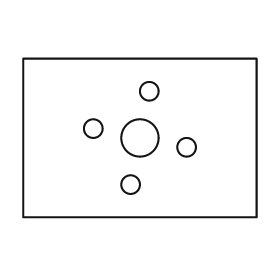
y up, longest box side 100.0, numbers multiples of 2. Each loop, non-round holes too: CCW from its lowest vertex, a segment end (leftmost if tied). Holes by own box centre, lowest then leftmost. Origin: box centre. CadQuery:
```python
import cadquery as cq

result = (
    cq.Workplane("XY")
    .moveTo(-50.0, -34.0)
    .lineTo(50.0, -34.0)
    .lineTo(50.0, 34.0)
    .lineTo(-50.0, 34.0)
    .close()
    .moveTo(-4.0, -20.0)
    .circle(4.0)
    .moveTo(20.0, -4.0)
    .circle(4.0)
    .moveTo(0.0, 0.0)
    .circle(8.0)
    .moveTo(-20.0, 4.0)
    .circle(4.0)
    .moveTo(4.0, 20.0)
    .circle(4.0)
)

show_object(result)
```